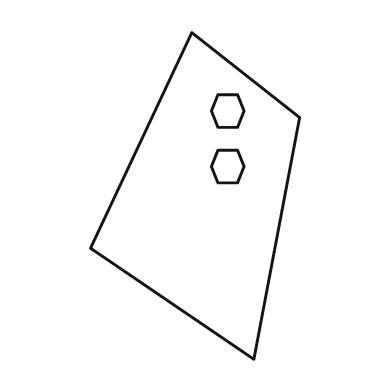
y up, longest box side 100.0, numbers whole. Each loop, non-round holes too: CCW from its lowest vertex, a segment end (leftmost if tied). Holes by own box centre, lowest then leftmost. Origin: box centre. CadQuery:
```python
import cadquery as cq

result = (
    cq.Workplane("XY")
    .moveTo(18.0, -50.0)
    .lineTo(32.0, 24.0)
    .lineTo(-1.0, 50.0)
    .lineTo(-32.0, -16.0)
    .close()
    .moveTo(7.0, 4.0)
    .lineTo(13.0, 4.0)
    .lineTo(15.0, 9.0)
    .lineTo(13.0, 14.0)
    .lineTo(7.0, 14.0)
    .lineTo(5.0, 9.0)
    .close()
    .moveTo(7.0, 21.0)
    .lineTo(13.0, 21.0)
    .lineTo(15.0, 26.0)
    .lineTo(13.0, 31.0)
    .lineTo(7.0, 31.0)
    .lineTo(5.0, 26.0)
    .close()
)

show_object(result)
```